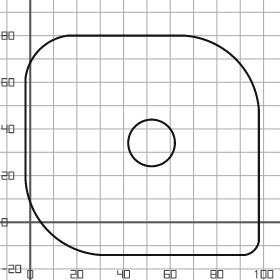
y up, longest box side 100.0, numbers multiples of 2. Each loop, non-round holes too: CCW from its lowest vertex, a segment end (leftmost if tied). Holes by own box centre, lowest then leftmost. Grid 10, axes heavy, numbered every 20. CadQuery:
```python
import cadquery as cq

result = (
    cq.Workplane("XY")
    .moveTo(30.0, -14.0)
    .lineTo(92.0, -14.0)
    .threePointArc((96.0, -12.0), (98.0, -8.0))
    .lineTo(98.0, 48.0)
    .threePointArc((88.0, 70.0), (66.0, 80.0))
    .lineTo(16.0, 80.0)
    .threePointArc((4.0, 74.0), (-2.0, 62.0))
    .lineTo(-2.0, 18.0)
    .threePointArc((8.0, -4.0), (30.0, -14.0))
    .close()
    .moveTo(52.0, 34.0)
    .circle(10.0)
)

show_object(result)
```